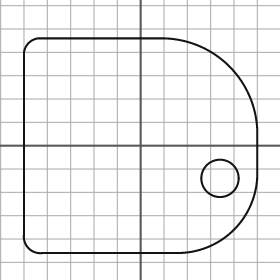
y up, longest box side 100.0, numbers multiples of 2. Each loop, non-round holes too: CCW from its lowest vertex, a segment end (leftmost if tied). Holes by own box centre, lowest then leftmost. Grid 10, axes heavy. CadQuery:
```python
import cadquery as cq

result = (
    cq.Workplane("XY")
    .moveTo(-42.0, -46.0)
    .lineTo(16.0, -46.0)
    .threePointArc((40.0, -36.0), (50.0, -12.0))
    .lineTo(50.0, 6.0)
    .threePointArc((38.0, 34.0), (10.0, 46.0))
    .lineTo(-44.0, 46.0)
    .threePointArc((-48.0, 44.0), (-50.0, 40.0))
    .lineTo(-50.0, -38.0)
    .threePointArc((-48.0, -44.0), (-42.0, -46.0))
    .close()
    .moveTo(34.0, -14.0)
    .circle(8.0)
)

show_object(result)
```